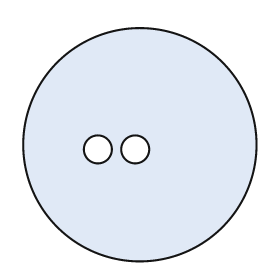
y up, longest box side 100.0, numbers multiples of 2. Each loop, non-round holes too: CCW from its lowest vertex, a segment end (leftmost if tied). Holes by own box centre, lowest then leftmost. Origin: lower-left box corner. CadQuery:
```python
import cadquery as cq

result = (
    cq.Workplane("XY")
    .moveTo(50.0, 50.0)
    .circle(50.0)
    .moveTo(32.0, 48.0)
    .circle(6.0)
    .moveTo(48.0, 48.0)
    .circle(6.0)
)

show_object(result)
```